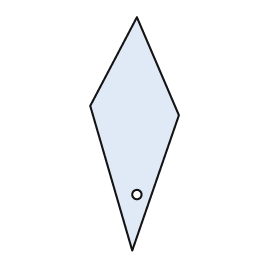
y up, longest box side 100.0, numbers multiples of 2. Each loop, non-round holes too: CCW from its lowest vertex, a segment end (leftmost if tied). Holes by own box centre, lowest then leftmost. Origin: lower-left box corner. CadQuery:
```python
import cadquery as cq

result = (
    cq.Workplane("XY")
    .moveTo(18.0, 0.0)
    .lineTo(38.0, 58.0)
    .lineTo(20.0, 100.0)
    .lineTo(0.0, 62.0)
    .close()
    .moveTo(20.0, 24.0)
    .circle(2.0)
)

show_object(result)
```